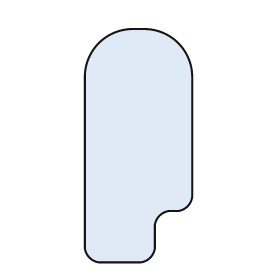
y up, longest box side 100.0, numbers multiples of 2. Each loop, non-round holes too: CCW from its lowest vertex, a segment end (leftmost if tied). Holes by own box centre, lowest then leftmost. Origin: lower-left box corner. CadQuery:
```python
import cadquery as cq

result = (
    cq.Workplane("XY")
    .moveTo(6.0, 0.0)
    .lineTo(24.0, 0.0)
    .threePointArc((28.0, 2.0), (30.0, 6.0))
    .lineTo(30.0, 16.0)
    .threePointArc((32.0, 20.0), (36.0, 22.0))
    .lineTo(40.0, 22.0)
    .threePointArc((44.0, 24.0), (46.0, 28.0))
    .lineTo(46.0, 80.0)
    .threePointArc((40.0, 94.0), (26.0, 100.0))
    .lineTo(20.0, 100.0)
    .threePointArc((6.0, 94.0), (0.0, 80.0))
    .lineTo(0.0, 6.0)
    .threePointArc((2.0, 2.0), (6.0, 0.0))
    .close()
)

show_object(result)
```